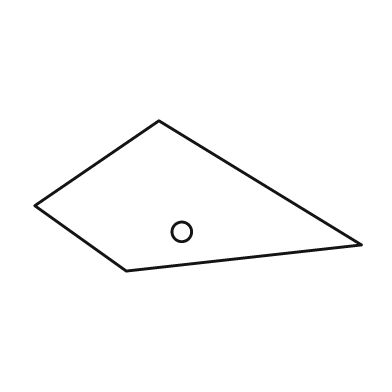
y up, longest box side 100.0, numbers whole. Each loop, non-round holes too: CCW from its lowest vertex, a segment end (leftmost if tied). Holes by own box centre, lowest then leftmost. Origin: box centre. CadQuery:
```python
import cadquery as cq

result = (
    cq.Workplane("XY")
    .moveTo(-22.0, -23.0)
    .lineTo(50.0, -15.0)
    .lineTo(-12.0, 23.0)
    .lineTo(-50.0, -3.0)
    .close()
    .moveTo(-5.0, -11.0)
    .circle(3.0)
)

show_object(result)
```